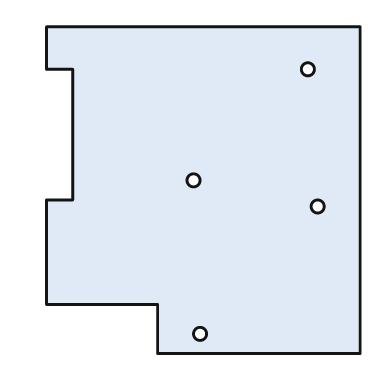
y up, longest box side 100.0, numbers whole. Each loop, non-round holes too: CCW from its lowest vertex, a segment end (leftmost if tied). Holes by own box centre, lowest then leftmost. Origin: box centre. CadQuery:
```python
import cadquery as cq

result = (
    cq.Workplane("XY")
    .moveTo(-14.0, -50.0)
    .lineTo(48.0, -50.0)
    .lineTo(48.0, 50.0)
    .lineTo(-48.0, 50.0)
    .lineTo(-48.0, 37.0)
    .lineTo(-40.0, 37.0)
    .lineTo(-40.0, -3.0)
    .lineTo(-48.0, -3.0)
    .lineTo(-48.0, -35.0)
    .lineTo(-14.0, -35.0)
    .close()
    .moveTo(-1.0, -44.0)
    .circle(2.0)
    .moveTo(35.0, -5.0)
    .circle(2.0)
    .moveTo(-3.0, 3.0)
    .circle(2.0)
    .moveTo(32.0, 37.0)
    .circle(2.0)
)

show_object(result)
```